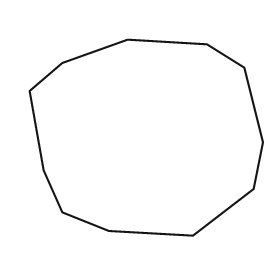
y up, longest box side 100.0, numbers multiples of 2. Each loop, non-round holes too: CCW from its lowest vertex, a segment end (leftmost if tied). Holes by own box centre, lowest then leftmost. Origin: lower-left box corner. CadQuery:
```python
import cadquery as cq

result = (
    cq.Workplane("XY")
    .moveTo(70.0, 0.0)
    .lineTo(96.0, 20.0)
    .lineTo(100.0, 40.0)
    .lineTo(92.0, 72.0)
    .lineTo(76.0, 82.0)
    .lineTo(42.0, 84.0)
    .lineTo(14.0, 74.0)
    .lineTo(0.0, 62.0)
    .lineTo(6.0, 28.0)
    .lineTo(14.0, 10.0)
    .lineTo(34.0, 2.0)
    .close()
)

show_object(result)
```